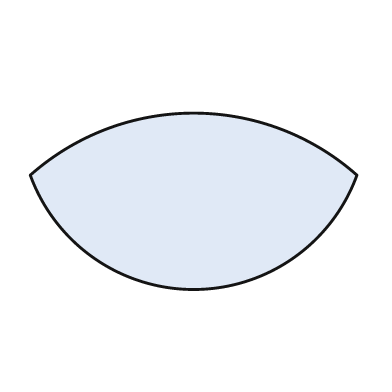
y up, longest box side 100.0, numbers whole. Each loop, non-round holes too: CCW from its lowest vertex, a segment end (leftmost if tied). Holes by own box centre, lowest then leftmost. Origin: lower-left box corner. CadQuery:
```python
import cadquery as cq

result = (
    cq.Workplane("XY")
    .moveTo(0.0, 35.0)
    .threePointArc((50.0, 0.0), (100.0, 35.0))
    .threePointArc((50.0, 54.0), (0.0, 35.0))
    .close()
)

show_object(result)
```